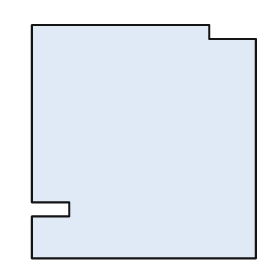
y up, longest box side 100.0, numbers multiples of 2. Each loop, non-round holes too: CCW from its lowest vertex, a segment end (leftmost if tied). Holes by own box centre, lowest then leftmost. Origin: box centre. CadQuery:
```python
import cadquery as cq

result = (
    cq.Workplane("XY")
    .moveTo(-48.0, -50.0)
    .lineTo(48.0, -50.0)
    .lineTo(48.0, 44.0)
    .lineTo(28.0, 44.0)
    .lineTo(28.0, 50.0)
    .lineTo(-48.0, 50.0)
    .lineTo(-48.0, -26.0)
    .lineTo(-32.0, -26.0)
    .lineTo(-32.0, -32.0)
    .lineTo(-48.0, -32.0)
    .close()
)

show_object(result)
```